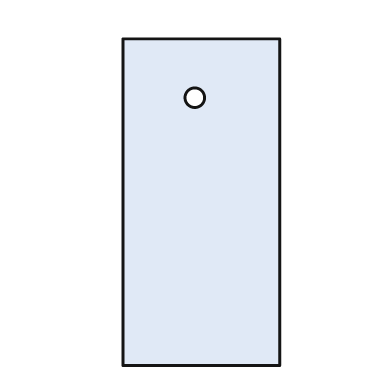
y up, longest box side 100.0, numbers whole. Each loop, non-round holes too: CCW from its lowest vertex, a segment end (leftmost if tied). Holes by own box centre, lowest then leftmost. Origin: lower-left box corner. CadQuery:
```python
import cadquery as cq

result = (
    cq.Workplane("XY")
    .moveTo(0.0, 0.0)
    .lineTo(48.0, 0.0)
    .lineTo(48.0, 100.0)
    .lineTo(0.0, 100.0)
    .close()
    .moveTo(22.0, 82.0)
    .circle(3.0)
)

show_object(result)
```